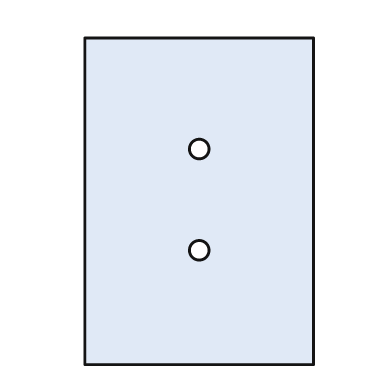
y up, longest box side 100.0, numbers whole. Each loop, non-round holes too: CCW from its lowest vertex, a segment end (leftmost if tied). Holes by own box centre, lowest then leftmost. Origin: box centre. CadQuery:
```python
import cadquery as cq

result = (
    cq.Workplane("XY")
    .moveTo(-35.0, -50.0)
    .lineTo(35.0, -50.0)
    .lineTo(35.0, 50.0)
    .lineTo(-35.0, 50.0)
    .close()
    .moveTo(0.0, -15.0)
    .circle(3.0)
    .moveTo(0.0, 16.0)
    .circle(3.0)
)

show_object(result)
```